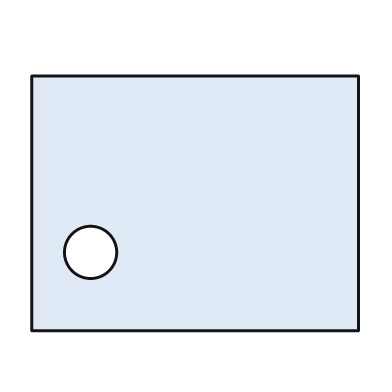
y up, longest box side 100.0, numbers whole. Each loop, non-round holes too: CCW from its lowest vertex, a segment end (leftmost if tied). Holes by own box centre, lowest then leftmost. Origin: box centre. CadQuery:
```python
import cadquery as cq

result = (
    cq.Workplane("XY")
    .moveTo(-50.0, -39.0)
    .lineTo(50.0, -39.0)
    .lineTo(50.0, 39.0)
    .lineTo(-50.0, 39.0)
    .close()
    .moveTo(-32.0, -15.0)
    .circle(8.0)
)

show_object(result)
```